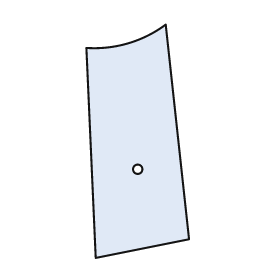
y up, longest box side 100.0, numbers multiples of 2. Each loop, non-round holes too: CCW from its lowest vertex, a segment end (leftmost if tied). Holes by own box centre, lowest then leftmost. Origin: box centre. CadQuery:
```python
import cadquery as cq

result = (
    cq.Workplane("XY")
    .moveTo(-18.0, -50.0)
    .lineTo(22.0, -42.0)
    .lineTo(12.0, 50.0)
    .threePointArc((-4.0, 42.0), (-22.0, 40.0))
    .close()
    .moveTo(0.0, -12.0)
    .circle(2.0)
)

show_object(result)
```